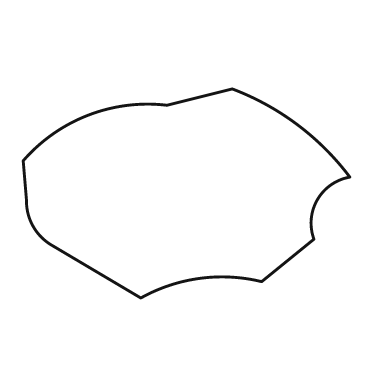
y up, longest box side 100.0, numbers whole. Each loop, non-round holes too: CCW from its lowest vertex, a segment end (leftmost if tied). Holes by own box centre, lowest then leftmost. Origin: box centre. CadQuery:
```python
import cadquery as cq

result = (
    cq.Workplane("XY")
    .moveTo(-14.0, -32.0)
    .threePointArc((4.0, -26.0), (23.0, -27.0))
    .lineTo(39.0, -14.0)
    .threePointArc((40.0, -2.0), (50.0, 5.0))
    .threePointArc((34.0, 21.0), (14.0, 32.0))
    .lineTo(-6.0, 27.0)
    .threePointArc((-30.0, 24.0), (-50.0, 10.0))
    .lineTo(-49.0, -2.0)
    .threePointArc((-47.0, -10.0), (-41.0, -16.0))
    .close()
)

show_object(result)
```